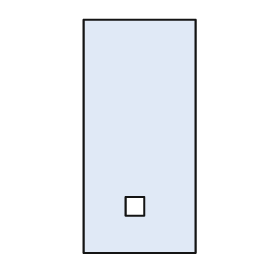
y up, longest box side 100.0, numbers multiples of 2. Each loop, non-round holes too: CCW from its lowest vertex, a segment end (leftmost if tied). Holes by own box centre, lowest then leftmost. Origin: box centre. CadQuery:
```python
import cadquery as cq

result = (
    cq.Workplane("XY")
    .moveTo(-24.0, -50.0)
    .lineTo(24.0, -50.0)
    .lineTo(24.0, 50.0)
    .lineTo(-24.0, 50.0)
    .close()
    .moveTo(-6.0, -34.0)
    .lineTo(2.0, -34.0)
    .lineTo(2.0, -26.0)
    .lineTo(-6.0, -26.0)
    .close()
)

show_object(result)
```